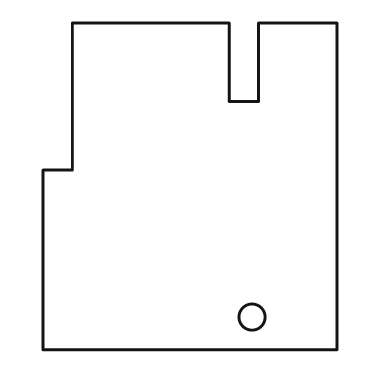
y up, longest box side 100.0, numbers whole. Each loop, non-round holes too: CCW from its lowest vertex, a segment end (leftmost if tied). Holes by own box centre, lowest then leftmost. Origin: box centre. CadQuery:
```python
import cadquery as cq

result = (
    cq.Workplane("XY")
    .moveTo(-45.0, -50.0)
    .lineTo(45.0, -50.0)
    .lineTo(45.0, 50.0)
    .lineTo(21.0, 50.0)
    .lineTo(21.0, 26.0)
    .lineTo(12.0, 26.0)
    .lineTo(12.0, 50.0)
    .lineTo(-36.0, 50.0)
    .lineTo(-36.0, 5.0)
    .lineTo(-45.0, 5.0)
    .close()
    .moveTo(19.0, -40.0)
    .circle(4.0)
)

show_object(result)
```